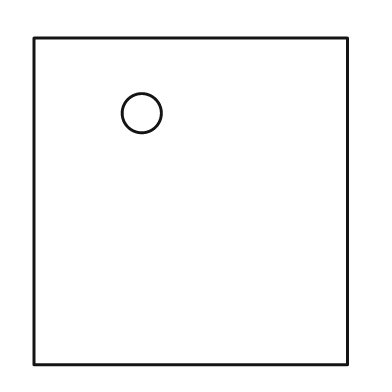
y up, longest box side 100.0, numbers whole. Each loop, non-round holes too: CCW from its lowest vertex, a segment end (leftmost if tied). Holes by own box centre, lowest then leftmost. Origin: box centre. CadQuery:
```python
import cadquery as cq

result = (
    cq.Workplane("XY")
    .moveTo(-48.0, -50.0)
    .lineTo(48.0, -50.0)
    .lineTo(48.0, 50.0)
    .lineTo(-48.0, 50.0)
    .close()
    .moveTo(-15.0, 27.0)
    .circle(6.0)
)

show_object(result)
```